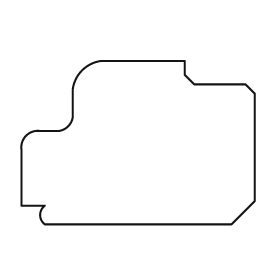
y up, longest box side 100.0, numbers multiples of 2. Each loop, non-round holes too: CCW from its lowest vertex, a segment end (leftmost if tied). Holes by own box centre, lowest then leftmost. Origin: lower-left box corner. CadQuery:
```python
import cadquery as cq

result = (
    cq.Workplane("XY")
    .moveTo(10.0, 0.0)
    .lineTo(90.0, 0.0)
    .lineTo(100.0, 10.0)
    .lineTo(100.0, 56.0)
    .lineTo(96.0, 60.0)
    .lineTo(74.0, 60.0)
    .lineTo(70.0, 64.0)
    .lineTo(70.0, 70.0)
    .lineTo(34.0, 70.0)
    .threePointArc((26.0, 66.0), (22.0, 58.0))
    .lineTo(22.0, 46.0)
    .threePointArc((20.0, 42.0), (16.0, 40.0))
    .lineTo(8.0, 40.0)
    .threePointArc((2.0, 38.0), (0.0, 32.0))
    .lineTo(0.0, 8.0)
    .lineTo(10.0, 8.0)
    .threePointArc((8.0, 4.0), (10.0, 0.0))
    .close()
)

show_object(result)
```